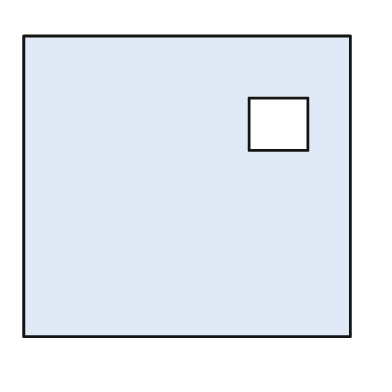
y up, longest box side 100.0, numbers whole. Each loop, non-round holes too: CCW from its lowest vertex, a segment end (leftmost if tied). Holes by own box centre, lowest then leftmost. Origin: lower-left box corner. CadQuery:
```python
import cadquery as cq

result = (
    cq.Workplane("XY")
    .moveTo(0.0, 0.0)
    .lineTo(100.0, 0.0)
    .lineTo(100.0, 92.0)
    .lineTo(0.0, 92.0)
    .close()
    .moveTo(69.0, 57.0)
    .lineTo(87.0, 57.0)
    .lineTo(87.0, 73.0)
    .lineTo(69.0, 73.0)
    .close()
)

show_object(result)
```